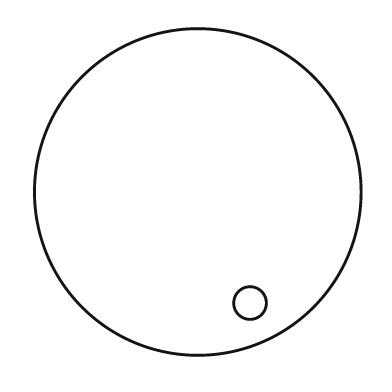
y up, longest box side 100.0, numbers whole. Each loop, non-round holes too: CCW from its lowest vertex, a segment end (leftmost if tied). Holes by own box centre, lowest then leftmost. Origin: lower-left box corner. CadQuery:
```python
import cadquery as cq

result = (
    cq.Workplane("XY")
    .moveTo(50.0, 50.0)
    .circle(50.0)
    .moveTo(66.0, 16.0)
    .circle(5.0)
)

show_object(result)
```